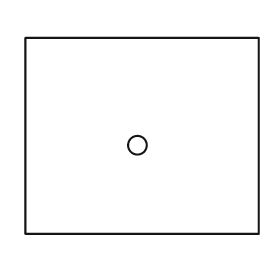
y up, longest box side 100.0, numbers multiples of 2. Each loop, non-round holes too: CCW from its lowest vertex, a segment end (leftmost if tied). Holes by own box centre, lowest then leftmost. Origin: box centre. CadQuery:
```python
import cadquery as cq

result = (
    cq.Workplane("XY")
    .moveTo(-50.0, -42.0)
    .lineTo(50.0, -42.0)
    .lineTo(50.0, 42.0)
    .lineTo(-50.0, 42.0)
    .close()
    .moveTo(-2.0, -4.0)
    .circle(4.0)
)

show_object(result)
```